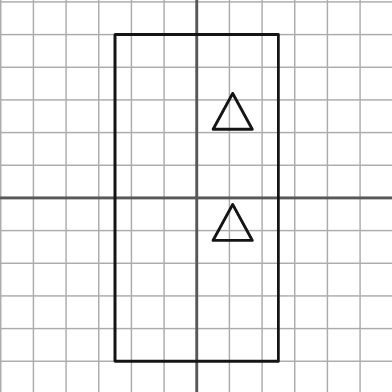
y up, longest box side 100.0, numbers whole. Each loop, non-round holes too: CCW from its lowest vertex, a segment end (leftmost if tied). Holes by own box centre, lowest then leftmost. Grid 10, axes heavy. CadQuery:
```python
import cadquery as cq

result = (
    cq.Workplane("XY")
    .moveTo(-25.0, -50.0)
    .lineTo(25.0, -50.0)
    .lineTo(25.0, 50.0)
    .lineTo(-25.0, 50.0)
    .close()
    .moveTo(5.0, -13.0)
    .lineTo(17.0, -13.0)
    .lineTo(11.0, -2.0)
    .close()
    .moveTo(5.0, 21.0)
    .lineTo(17.0, 21.0)
    .lineTo(11.0, 32.0)
    .close()
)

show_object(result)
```